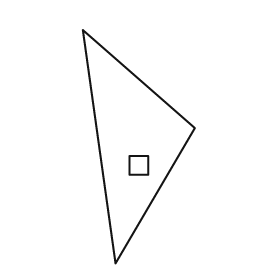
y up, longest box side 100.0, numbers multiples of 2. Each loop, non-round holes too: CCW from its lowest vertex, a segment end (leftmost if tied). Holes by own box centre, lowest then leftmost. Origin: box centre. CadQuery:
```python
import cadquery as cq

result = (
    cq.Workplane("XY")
    .moveTo(-10.0, -50.0)
    .lineTo(24.0, 8.0)
    .lineTo(-24.0, 50.0)
    .close()
    .moveTo(-4.0, -12.0)
    .lineTo(4.0, -12.0)
    .lineTo(4.0, -4.0)
    .lineTo(-4.0, -4.0)
    .close()
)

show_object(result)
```